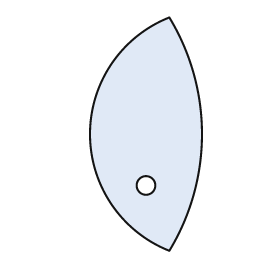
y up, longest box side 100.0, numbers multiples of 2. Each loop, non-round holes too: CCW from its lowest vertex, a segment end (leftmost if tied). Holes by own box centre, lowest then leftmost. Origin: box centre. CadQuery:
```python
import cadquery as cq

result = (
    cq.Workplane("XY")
    .moveTo(10.0, -50.0)
    .threePointArc((24.0, 0.0), (10.0, 50.0))
    .threePointArc((-24.0, 0.0), (10.0, -50.0))
    .close()
    .moveTo(0.0, -22.0)
    .circle(4.0)
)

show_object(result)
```